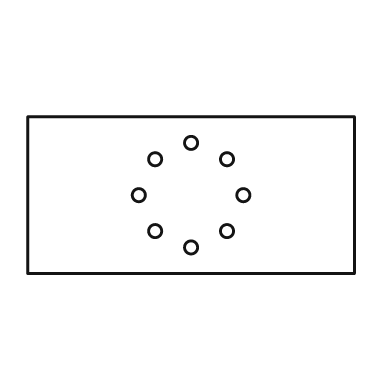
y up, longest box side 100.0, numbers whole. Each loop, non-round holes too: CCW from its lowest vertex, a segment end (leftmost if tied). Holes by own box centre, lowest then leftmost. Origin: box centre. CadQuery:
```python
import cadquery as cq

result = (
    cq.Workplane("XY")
    .moveTo(-50.0, -24.0)
    .lineTo(50.0, -24.0)
    .lineTo(50.0, 24.0)
    .lineTo(-50.0, 24.0)
    .close()
    .moveTo(0.0, -16.0)
    .circle(2.0)
    .moveTo(-11.0, -11.0)
    .circle(2.0)
    .moveTo(11.0, -11.0)
    .circle(2.0)
    .moveTo(-16.0, 0.0)
    .circle(2.0)
    .moveTo(16.0, 0.0)
    .circle(2.0)
    .moveTo(-11.0, 11.0)
    .circle(2.0)
    .moveTo(11.0, 11.0)
    .circle(2.0)
    .moveTo(0.0, 16.0)
    .circle(2.0)
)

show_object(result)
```